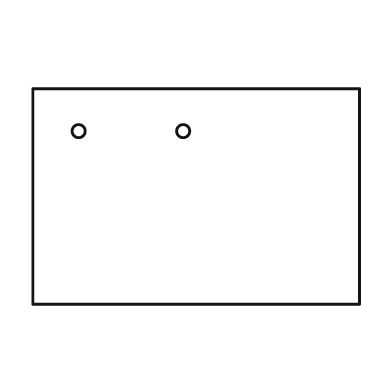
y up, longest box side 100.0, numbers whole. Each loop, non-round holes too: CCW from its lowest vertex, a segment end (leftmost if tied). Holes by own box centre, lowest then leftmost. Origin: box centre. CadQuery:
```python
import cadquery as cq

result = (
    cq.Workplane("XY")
    .moveTo(-50.0, -33.0)
    .lineTo(50.0, -33.0)
    .lineTo(50.0, 33.0)
    .lineTo(-50.0, 33.0)
    .close()
    .moveTo(-36.0, 20.0)
    .circle(2.0)
    .moveTo(-4.0, 20.0)
    .circle(2.0)
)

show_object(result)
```